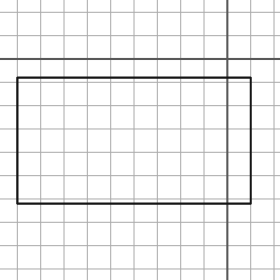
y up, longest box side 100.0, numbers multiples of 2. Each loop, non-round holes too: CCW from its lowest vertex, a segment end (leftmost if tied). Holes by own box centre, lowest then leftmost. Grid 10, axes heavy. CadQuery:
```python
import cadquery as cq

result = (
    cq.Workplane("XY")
    .moveTo(-90.0, -62.0)
    .lineTo(10.0, -62.0)
    .lineTo(10.0, -8.0)
    .lineTo(-90.0, -8.0)
    .close()
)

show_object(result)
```